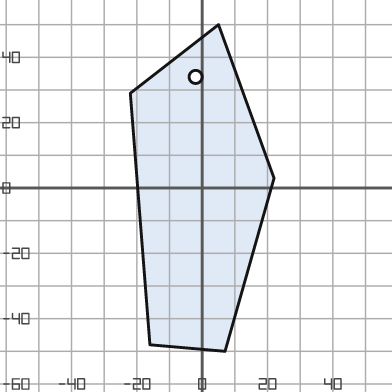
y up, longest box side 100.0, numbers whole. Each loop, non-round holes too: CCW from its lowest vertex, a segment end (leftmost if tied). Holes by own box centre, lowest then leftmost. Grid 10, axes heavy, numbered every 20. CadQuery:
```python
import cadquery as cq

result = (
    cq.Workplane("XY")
    .moveTo(7.0, -50.0)
    .lineTo(22.0, 3.0)
    .lineTo(5.0, 50.0)
    .lineTo(-22.0, 29.0)
    .lineTo(-16.0, -48.0)
    .close()
    .moveTo(-2.0, 34.0)
    .circle(2.0)
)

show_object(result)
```